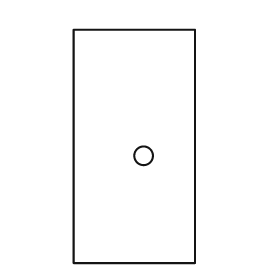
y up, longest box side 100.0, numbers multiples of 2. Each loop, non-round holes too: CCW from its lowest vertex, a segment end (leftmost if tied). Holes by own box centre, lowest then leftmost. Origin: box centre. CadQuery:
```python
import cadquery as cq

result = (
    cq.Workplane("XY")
    .moveTo(-26.0, -50.0)
    .lineTo(26.0, -50.0)
    .lineTo(26.0, 50.0)
    .lineTo(-26.0, 50.0)
    .close()
    .moveTo(4.0, -4.0)
    .circle(4.0)
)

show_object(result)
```